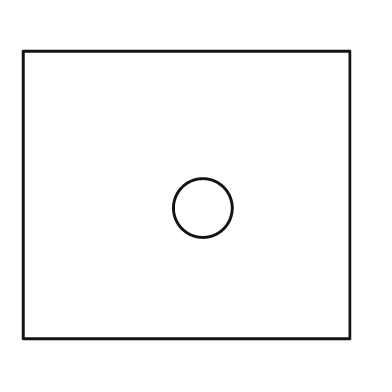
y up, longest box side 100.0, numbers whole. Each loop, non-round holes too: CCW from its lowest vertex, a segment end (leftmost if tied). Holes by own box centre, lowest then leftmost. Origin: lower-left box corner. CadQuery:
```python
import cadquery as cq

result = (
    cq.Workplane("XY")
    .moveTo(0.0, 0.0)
    .lineTo(100.0, 0.0)
    .lineTo(100.0, 88.0)
    .lineTo(0.0, 88.0)
    .close()
    .moveTo(55.0, 40.0)
    .circle(9.0)
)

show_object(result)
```